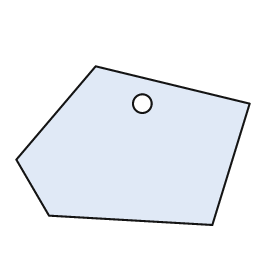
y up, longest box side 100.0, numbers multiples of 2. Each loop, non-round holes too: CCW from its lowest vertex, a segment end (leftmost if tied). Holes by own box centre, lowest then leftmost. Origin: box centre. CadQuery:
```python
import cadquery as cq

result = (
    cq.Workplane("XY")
    .moveTo(34.0, -34.0)
    .lineTo(50.0, 18.0)
    .lineTo(-16.0, 34.0)
    .lineTo(-50.0, -6.0)
    .lineTo(-36.0, -30.0)
    .close()
    .moveTo(4.0, 18.0)
    .circle(4.0)
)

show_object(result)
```